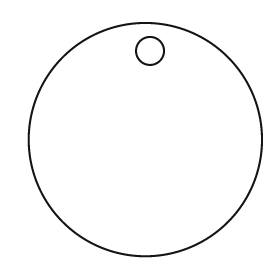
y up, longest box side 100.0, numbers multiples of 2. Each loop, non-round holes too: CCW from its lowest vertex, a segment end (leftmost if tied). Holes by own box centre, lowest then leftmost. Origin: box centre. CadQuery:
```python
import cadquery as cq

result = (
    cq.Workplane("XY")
    .moveTo(0.0, 0.0)
    .circle(50.0)
    .moveTo(2.0, 38.0)
    .circle(6.0)
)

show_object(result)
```